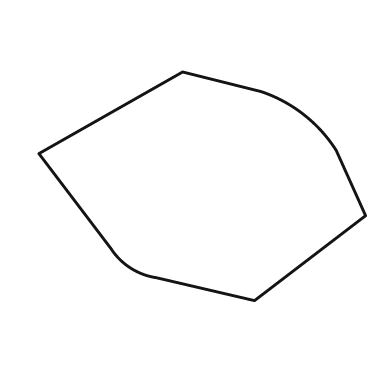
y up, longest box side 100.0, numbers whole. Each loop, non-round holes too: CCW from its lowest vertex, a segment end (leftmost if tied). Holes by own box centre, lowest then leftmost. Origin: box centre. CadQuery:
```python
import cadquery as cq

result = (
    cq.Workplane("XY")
    .moveTo(16.0, -35.0)
    .lineTo(50.0, -9.0)
    .lineTo(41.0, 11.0)
    .threePointArc((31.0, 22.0), (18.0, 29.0))
    .lineTo(-6.0, 35.0)
    .lineTo(-50.0, 10.0)
    .lineTo(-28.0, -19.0)
    .threePointArc((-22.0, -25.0), (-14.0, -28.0))
    .close()
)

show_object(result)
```